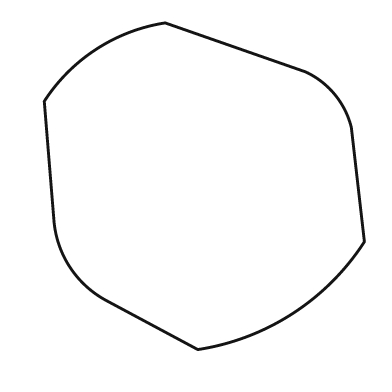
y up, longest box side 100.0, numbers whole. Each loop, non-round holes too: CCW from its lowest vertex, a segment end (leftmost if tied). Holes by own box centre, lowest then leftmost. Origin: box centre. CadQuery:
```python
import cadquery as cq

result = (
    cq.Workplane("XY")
    .moveTo(-2.0, -50.0)
    .threePointArc((27.0, -39.0), (49.0, -17.0))
    .lineTo(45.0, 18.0)
    .threePointArc((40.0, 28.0), (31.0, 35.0))
    .lineTo(-12.0, 50.0)
    .threePointArc((-33.0, 42.0), (-49.0, 26.0))
    .lineTo(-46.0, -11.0)
    .threePointArc((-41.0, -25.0), (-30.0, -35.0))
    .close()
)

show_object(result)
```